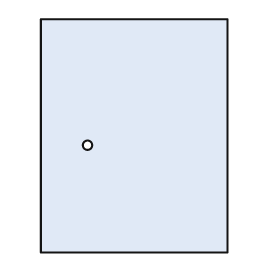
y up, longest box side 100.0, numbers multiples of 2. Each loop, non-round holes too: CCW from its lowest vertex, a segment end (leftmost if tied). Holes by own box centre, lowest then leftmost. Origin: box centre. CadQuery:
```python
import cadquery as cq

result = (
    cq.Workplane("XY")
    .moveTo(-40.0, -50.0)
    .lineTo(40.0, -50.0)
    .lineTo(40.0, 50.0)
    .lineTo(-40.0, 50.0)
    .close()
    .moveTo(-20.0, -4.0)
    .circle(2.0)
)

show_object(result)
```